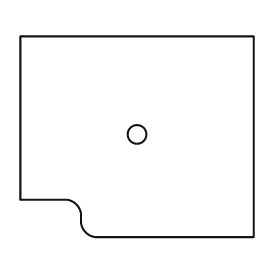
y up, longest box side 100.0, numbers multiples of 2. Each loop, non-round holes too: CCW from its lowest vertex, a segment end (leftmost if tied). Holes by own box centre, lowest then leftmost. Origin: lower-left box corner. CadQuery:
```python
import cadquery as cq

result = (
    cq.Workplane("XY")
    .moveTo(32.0, 0.0)
    .lineTo(100.0, 0.0)
    .lineTo(100.0, 86.0)
    .lineTo(0.0, 86.0)
    .lineTo(0.0, 16.0)
    .lineTo(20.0, 16.0)
    .threePointArc((24.0, 14.0), (26.0, 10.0))
    .lineTo(26.0, 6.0)
    .threePointArc((28.0, 2.0), (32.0, 0.0))
    .close()
    .moveTo(50.0, 44.0)
    .circle(4.0)
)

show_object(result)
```